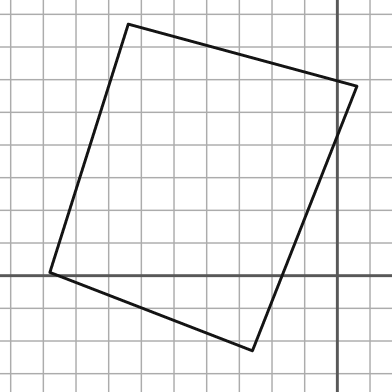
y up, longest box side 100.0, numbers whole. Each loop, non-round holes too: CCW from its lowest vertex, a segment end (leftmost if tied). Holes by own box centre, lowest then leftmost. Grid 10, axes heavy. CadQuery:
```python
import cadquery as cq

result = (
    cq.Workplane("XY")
    .moveTo(-26.0, -23.0)
    .lineTo(6.0, 58.0)
    .lineTo(-64.0, 77.0)
    .lineTo(-88.0, 1.0)
    .close()
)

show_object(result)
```